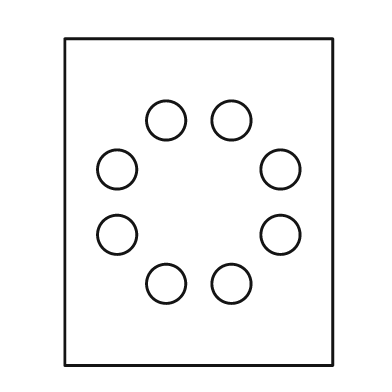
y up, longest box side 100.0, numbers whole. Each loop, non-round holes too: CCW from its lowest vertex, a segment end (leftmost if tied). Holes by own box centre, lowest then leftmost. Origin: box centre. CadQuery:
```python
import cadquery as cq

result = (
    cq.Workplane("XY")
    .moveTo(-41.0, -50.0)
    .lineTo(41.0, -50.0)
    .lineTo(41.0, 50.0)
    .lineTo(-41.0, 50.0)
    .close()
    .moveTo(-10.0, -25.0)
    .circle(6.0)
    .moveTo(10.0, -25.0)
    .circle(6.0)
    .moveTo(-25.0, -10.0)
    .circle(6.0)
    .moveTo(25.0, -10.0)
    .circle(6.0)
    .moveTo(-25.0, 10.0)
    .circle(6.0)
    .moveTo(25.0, 10.0)
    .circle(6.0)
    .moveTo(-10.0, 25.0)
    .circle(6.0)
    .moveTo(10.0, 25.0)
    .circle(6.0)
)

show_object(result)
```